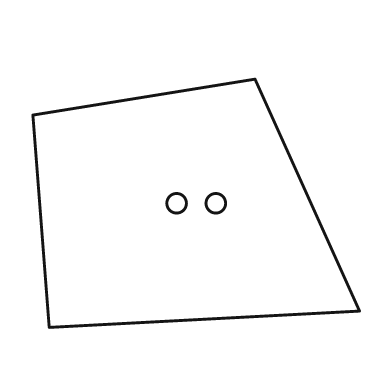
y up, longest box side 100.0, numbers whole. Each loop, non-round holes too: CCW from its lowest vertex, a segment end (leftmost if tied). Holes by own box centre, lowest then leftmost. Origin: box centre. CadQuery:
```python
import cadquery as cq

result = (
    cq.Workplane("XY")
    .moveTo(-45.0, -38.0)
    .lineTo(50.0, -33.0)
    .lineTo(18.0, 38.0)
    .lineTo(-50.0, 27.0)
    .close()
    .moveTo(-6.0, 0.0)
    .circle(3.0)
    .moveTo(6.0, 0.0)
    .circle(3.0)
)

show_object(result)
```